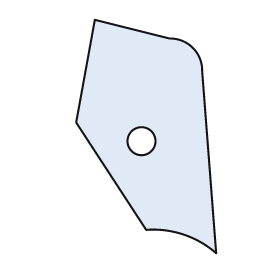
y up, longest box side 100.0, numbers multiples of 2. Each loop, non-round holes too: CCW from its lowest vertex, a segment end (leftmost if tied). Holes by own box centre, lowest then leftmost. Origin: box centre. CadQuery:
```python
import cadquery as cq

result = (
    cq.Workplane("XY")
    .moveTo(30.0, -50.0)
    .lineTo(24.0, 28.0)
    .threePointArc((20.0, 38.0), (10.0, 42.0))
    .lineTo(-22.0, 50.0)
    .lineTo(-30.0, 6.0)
    .lineTo(0.0, -40.0)
    .threePointArc((16.0, -42.0), (30.0, -50.0))
    .close()
    .moveTo(-2.0, -2.0)
    .circle(6.0)
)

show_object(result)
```